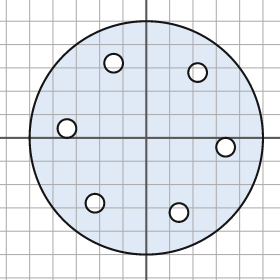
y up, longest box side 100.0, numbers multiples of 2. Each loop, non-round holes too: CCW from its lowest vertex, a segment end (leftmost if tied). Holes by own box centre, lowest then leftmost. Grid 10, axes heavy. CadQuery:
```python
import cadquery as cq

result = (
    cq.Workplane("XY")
    .moveTo(0.0, 0.0)
    .circle(50.0)
    .moveTo(14.0, -32.0)
    .circle(4.0)
    .moveTo(-22.0, -28.0)
    .circle(4.0)
    .moveTo(34.0, -4.0)
    .circle(4.0)
    .moveTo(-34.0, 4.0)
    .circle(4.0)
    .moveTo(22.0, 28.0)
    .circle(4.0)
    .moveTo(-14.0, 32.0)
    .circle(4.0)
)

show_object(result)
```